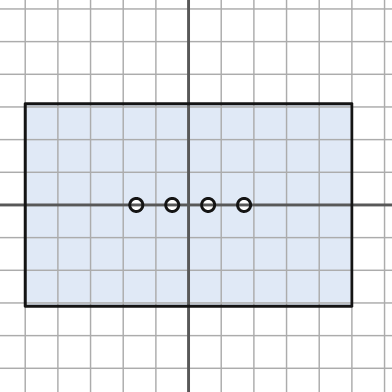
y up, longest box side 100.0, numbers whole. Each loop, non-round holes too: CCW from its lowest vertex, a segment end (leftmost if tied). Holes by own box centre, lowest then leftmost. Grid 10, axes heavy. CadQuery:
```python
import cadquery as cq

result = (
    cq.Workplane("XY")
    .moveTo(-50.0, -31.0)
    .lineTo(50.0, -31.0)
    .lineTo(50.0, 31.0)
    .lineTo(-50.0, 31.0)
    .close()
    .moveTo(-16.0, 0.0)
    .circle(2.0)
    .moveTo(-5.0, 0.0)
    .circle(2.0)
    .moveTo(6.0, 0.0)
    .circle(2.0)
    .moveTo(17.0, 0.0)
    .circle(2.0)
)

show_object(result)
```